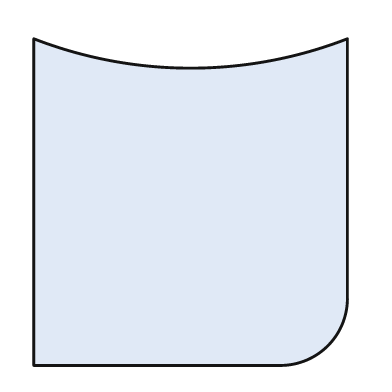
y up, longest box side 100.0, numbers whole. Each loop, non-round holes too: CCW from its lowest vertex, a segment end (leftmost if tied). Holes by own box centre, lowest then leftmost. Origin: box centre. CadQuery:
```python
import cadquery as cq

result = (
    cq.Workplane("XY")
    .moveTo(-48.0, -50.0)
    .lineTo(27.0, -50.0)
    .threePointArc((42.0, -44.0), (48.0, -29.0))
    .lineTo(48.0, 50.0)
    .threePointArc((0.0, 41.0), (-48.0, 50.0))
    .close()
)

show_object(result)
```